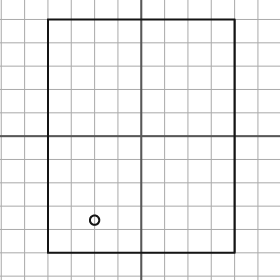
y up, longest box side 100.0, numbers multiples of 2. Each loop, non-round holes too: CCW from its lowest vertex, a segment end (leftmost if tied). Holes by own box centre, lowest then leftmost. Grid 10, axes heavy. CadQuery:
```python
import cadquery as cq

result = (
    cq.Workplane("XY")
    .moveTo(-40.0, -50.0)
    .lineTo(40.0, -50.0)
    .lineTo(40.0, 50.0)
    .lineTo(-40.0, 50.0)
    .close()
    .moveTo(-20.0, -36.0)
    .circle(2.0)
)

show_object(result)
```